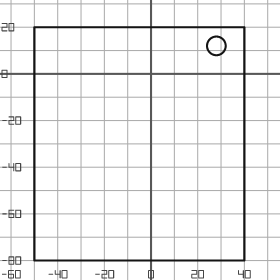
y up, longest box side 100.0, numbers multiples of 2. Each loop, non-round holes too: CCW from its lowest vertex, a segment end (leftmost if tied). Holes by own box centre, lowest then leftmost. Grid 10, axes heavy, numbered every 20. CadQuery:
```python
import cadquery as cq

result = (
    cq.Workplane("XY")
    .moveTo(-50.0, -80.0)
    .lineTo(40.0, -80.0)
    .lineTo(40.0, 20.0)
    .lineTo(-50.0, 20.0)
    .close()
    .moveTo(28.0, 12.0)
    .circle(4.0)
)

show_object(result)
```